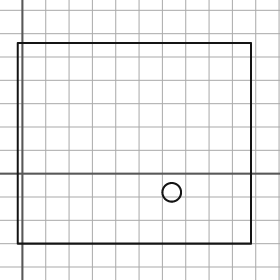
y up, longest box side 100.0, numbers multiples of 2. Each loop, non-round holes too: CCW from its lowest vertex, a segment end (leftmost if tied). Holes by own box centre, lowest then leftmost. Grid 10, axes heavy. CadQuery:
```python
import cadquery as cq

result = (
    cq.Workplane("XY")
    .moveTo(-2.0, -30.0)
    .lineTo(98.0, -30.0)
    .lineTo(98.0, 56.0)
    .lineTo(-2.0, 56.0)
    .close()
    .moveTo(64.0, -8.0)
    .circle(4.0)
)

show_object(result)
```